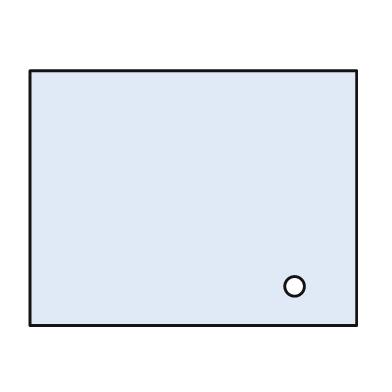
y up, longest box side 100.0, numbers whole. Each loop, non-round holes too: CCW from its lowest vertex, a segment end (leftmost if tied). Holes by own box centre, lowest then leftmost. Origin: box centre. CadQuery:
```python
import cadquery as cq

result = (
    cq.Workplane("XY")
    .moveTo(-50.0, -39.0)
    .lineTo(50.0, -39.0)
    .lineTo(50.0, 39.0)
    .lineTo(-50.0, 39.0)
    .close()
    .moveTo(31.0, -27.0)
    .circle(3.0)
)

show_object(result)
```